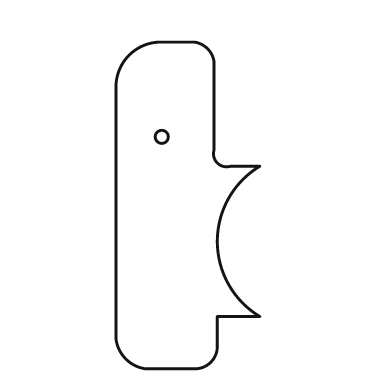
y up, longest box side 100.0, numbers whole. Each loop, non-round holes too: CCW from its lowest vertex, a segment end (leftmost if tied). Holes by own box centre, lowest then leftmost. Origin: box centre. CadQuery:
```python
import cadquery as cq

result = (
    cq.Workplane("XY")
    .moveTo(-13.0, -50.0)
    .lineTo(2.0, -50.0)
    .threePointArc((7.0, -48.0), (9.0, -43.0))
    .lineTo(9.0, -34.0)
    .lineTo(22.0, -34.0)
    .threePointArc((9.0, -11.0), (22.0, 12.0))
    .lineTo(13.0, 12.0)
    .threePointArc((9.0, 13.0), (8.0, 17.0))
    .lineTo(8.0, 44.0)
    .threePointArc((6.0, 48.0), (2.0, 50.0))
    .lineTo(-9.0, 50.0)
    .threePointArc((-18.0, 46.0), (-22.0, 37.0))
    .lineTo(-22.0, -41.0)
    .threePointArc((-19.0, -47.0), (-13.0, -50.0))
    .close()
    .moveTo(-8.0, 21.0)
    .circle(2.0)
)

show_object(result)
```